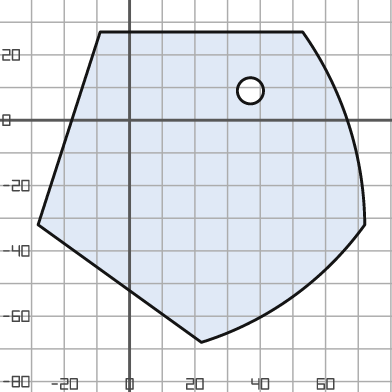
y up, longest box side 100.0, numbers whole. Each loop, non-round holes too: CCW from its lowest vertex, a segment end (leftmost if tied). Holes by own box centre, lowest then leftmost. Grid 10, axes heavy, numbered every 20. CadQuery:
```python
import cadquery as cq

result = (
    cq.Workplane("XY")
    .moveTo(22.0, -68.0)
    .threePointArc((50.0, -54.0), (72.0, -32.0))
    .threePointArc((67.0, -1.0), (53.0, 27.0))
    .lineTo(-9.0, 27.0)
    .lineTo(-28.0, -32.0)
    .close()
    .moveTo(37.0, 9.0)
    .circle(4.0)
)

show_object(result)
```